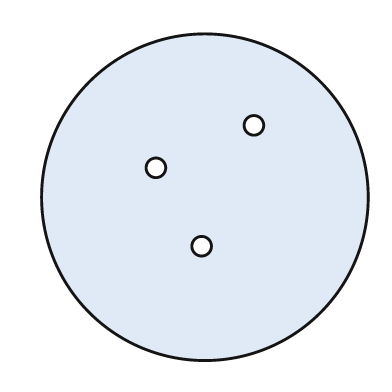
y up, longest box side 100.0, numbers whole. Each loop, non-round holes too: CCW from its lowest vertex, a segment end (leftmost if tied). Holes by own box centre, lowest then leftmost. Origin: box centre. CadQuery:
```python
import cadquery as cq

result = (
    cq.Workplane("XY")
    .moveTo(0.0, 0.0)
    .circle(50.0)
    .moveTo(-1.0, -15.0)
    .circle(3.0)
    .moveTo(-15.0, 9.0)
    .circle(3.0)
    .moveTo(15.0, 22.0)
    .circle(3.0)
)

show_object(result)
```